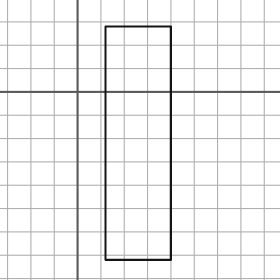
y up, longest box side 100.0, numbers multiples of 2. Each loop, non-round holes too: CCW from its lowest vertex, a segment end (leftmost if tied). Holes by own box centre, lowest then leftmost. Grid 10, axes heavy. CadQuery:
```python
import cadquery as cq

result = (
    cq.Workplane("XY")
    .moveTo(12.0, -72.0)
    .lineTo(40.0, -72.0)
    .lineTo(40.0, 28.0)
    .lineTo(12.0, 28.0)
    .close()
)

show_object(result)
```